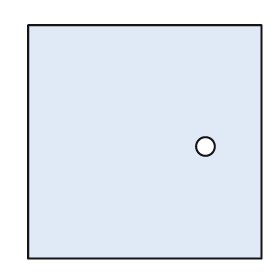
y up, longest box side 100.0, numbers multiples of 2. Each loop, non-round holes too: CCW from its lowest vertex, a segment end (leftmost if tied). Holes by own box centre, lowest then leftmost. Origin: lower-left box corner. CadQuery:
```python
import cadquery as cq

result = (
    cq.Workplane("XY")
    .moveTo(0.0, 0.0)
    .lineTo(100.0, 0.0)
    .lineTo(100.0, 100.0)
    .lineTo(0.0, 100.0)
    .close()
    .moveTo(76.0, 48.0)
    .circle(4.0)
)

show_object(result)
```